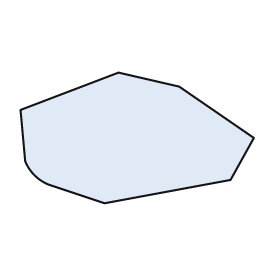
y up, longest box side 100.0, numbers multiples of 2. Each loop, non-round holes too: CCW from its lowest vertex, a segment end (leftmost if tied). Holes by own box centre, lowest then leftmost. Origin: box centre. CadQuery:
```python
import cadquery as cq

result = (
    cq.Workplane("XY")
    .moveTo(-14.0, -28.0)
    .lineTo(40.0, -18.0)
    .lineTo(50.0, 0.0)
    .lineTo(18.0, 22.0)
    .lineTo(-8.0, 28.0)
    .lineTo(-50.0, 12.0)
    .lineTo(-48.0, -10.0)
    .threePointArc((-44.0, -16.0), (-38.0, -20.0))
    .close()
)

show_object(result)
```